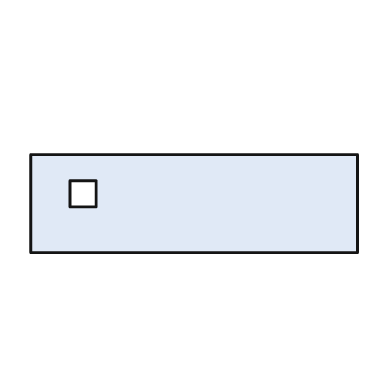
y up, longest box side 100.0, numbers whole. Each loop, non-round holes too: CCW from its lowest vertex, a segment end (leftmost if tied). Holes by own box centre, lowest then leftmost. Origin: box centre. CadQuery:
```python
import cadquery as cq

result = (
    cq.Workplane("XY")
    .moveTo(-50.0, -15.0)
    .lineTo(50.0, -15.0)
    .lineTo(50.0, 15.0)
    .lineTo(-50.0, 15.0)
    .close()
    .moveTo(-38.0, -1.0)
    .lineTo(-30.0, -1.0)
    .lineTo(-30.0, 7.0)
    .lineTo(-38.0, 7.0)
    .close()
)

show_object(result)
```